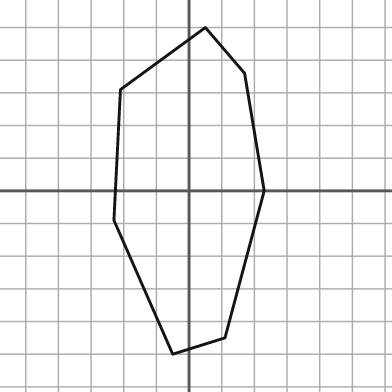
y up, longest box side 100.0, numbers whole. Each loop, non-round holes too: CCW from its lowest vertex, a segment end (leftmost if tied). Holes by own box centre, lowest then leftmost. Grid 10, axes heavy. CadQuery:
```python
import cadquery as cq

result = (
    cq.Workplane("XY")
    .moveTo(-5.0, -50.0)
    .lineTo(11.0, -45.0)
    .lineTo(23.0, 0.0)
    .lineTo(17.0, 36.0)
    .lineTo(5.0, 50.0)
    .lineTo(-21.0, 31.0)
    .lineTo(-23.0, -9.0)
    .close()
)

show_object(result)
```